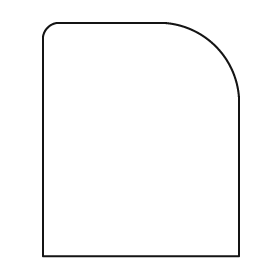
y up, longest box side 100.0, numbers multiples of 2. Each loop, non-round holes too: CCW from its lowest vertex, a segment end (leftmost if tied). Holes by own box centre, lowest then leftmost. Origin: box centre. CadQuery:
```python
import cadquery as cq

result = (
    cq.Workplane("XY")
    .moveTo(-42.0, -50.0)
    .lineTo(42.0, -50.0)
    .lineTo(42.0, 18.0)
    .threePointArc((32.0, 40.0), (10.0, 50.0))
    .lineTo(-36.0, 50.0)
    .threePointArc((-40.0, 48.0), (-42.0, 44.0))
    .close()
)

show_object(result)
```